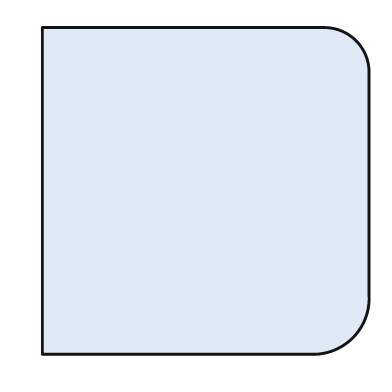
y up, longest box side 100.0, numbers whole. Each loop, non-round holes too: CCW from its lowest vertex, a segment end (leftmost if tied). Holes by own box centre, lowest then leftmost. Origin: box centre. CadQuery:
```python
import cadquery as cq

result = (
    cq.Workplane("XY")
    .moveTo(-50.0, -50.0)
    .lineTo(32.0, -50.0)
    .threePointArc((45.0, -45.0), (50.0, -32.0))
    .lineTo(50.0, 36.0)
    .threePointArc((46.0, 46.0), (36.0, 50.0))
    .lineTo(-50.0, 50.0)
    .close()
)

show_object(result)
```